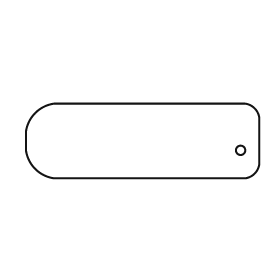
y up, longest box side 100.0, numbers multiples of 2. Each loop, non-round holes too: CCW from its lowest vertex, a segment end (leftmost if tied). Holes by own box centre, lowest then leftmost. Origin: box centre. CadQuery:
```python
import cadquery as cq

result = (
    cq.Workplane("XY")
    .moveTo(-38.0, -16.0)
    .lineTo(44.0, -16.0)
    .threePointArc((48.0, -14.0), (50.0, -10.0))
    .lineTo(50.0, 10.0)
    .threePointArc((48.0, 14.0), (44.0, 16.0))
    .lineTo(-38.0, 16.0)
    .threePointArc((-46.0, 12.0), (-50.0, 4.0))
    .lineTo(-50.0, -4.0)
    .threePointArc((-46.0, -12.0), (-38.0, -16.0))
    .close()
    .moveTo(42.0, -4.0)
    .circle(2.0)
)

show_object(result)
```